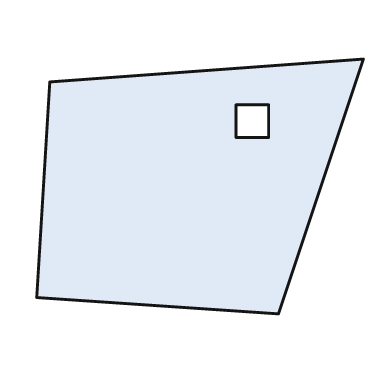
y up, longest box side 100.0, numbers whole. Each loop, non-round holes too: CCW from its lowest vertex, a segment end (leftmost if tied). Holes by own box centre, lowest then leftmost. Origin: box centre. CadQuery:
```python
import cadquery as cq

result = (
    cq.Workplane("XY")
    .moveTo(24.0, -39.0)
    .lineTo(50.0, 39.0)
    .lineTo(-46.0, 32.0)
    .lineTo(-50.0, -34.0)
    .close()
    .moveTo(11.0, 15.0)
    .lineTo(21.0, 15.0)
    .lineTo(21.0, 25.0)
    .lineTo(11.0, 25.0)
    .close()
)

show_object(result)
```